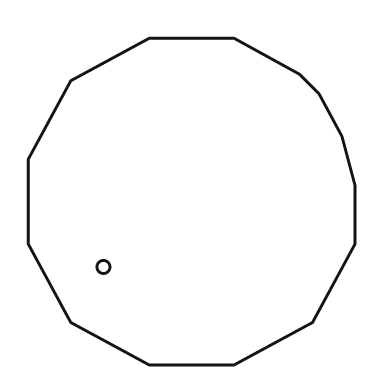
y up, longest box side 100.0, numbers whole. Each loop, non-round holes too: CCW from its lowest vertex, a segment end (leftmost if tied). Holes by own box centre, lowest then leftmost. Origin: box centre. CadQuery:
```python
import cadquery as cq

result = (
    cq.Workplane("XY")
    .moveTo(-13.0, -50.0)
    .lineTo(13.0, -50.0)
    .lineTo(37.0, -37.0)
    .lineTo(50.0, -13.0)
    .lineTo(50.0, 5.0)
    .lineTo(46.0, 20.0)
    .lineTo(39.0, 33.0)
    .lineTo(33.0, 39.0)
    .lineTo(13.0, 50.0)
    .lineTo(-13.0, 50.0)
    .lineTo(-37.0, 37.0)
    .lineTo(-50.0, 13.0)
    .lineTo(-50.0, -13.0)
    .lineTo(-37.0, -37.0)
    .close()
    .moveTo(-27.0, -20.0)
    .circle(2.0)
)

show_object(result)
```